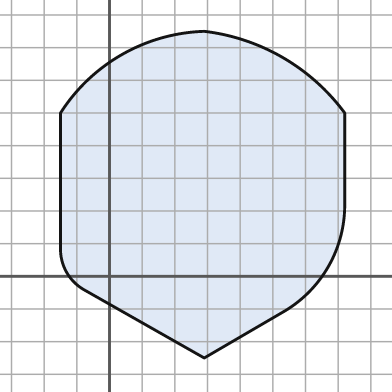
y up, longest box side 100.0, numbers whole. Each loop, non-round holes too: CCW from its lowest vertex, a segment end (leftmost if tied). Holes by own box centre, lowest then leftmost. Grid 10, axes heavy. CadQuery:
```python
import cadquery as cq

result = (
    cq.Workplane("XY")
    .moveTo(29.0, -25.0)
    .lineTo(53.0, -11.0)
    .threePointArc((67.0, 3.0), (72.0, 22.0))
    .lineTo(72.0, 50.0)
    .threePointArc((53.0, 67.0), (29.0, 75.0))
    .threePointArc((4.0, 68.0), (-15.0, 50.0))
    .lineTo(-15.0, 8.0)
    .threePointArc((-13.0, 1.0), (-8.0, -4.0))
    .close()
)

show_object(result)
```